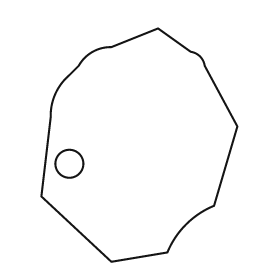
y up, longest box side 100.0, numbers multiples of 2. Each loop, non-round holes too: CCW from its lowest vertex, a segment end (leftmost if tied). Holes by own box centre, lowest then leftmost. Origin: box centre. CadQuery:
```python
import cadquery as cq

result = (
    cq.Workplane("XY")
    .moveTo(-12.0, -50.0)
    .lineTo(12.0, -46.0)
    .threePointArc((20.0, -34.0), (32.0, -26.0))
    .lineTo(42.0, 8.0)
    .lineTo(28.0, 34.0)
    .threePointArc((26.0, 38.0), (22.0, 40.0))
    .lineTo(8.0, 50.0)
    .lineTo(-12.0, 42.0)
    .threePointArc((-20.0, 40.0), (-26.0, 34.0))
    .lineTo(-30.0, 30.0)
    .threePointArc((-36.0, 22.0), (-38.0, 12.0))
    .lineTo(-42.0, -22.0)
    .close()
    .moveTo(-30.0, -8.0)
    .circle(6.0)
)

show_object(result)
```